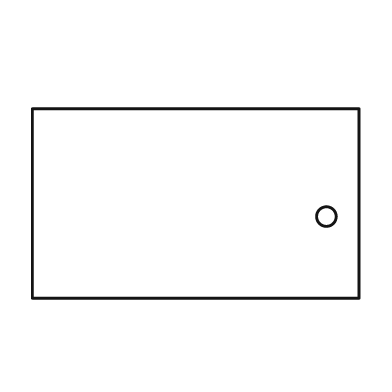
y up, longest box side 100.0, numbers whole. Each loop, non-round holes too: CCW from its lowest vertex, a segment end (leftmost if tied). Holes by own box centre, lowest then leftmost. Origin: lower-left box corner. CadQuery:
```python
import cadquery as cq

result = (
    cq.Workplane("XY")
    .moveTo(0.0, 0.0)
    .lineTo(100.0, 0.0)
    .lineTo(100.0, 58.0)
    .lineTo(0.0, 58.0)
    .close()
    .moveTo(90.0, 25.0)
    .circle(3.0)
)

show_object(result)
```